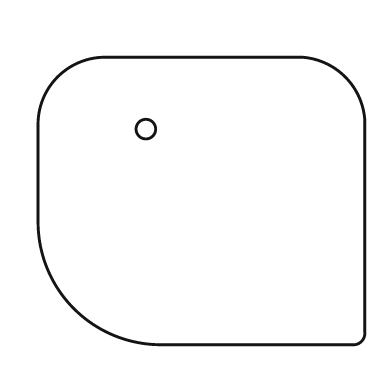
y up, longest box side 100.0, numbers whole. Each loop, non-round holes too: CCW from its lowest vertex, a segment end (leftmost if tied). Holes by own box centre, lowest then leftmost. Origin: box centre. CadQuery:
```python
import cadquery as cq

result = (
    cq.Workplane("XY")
    .moveTo(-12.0, -44.0)
    .lineTo(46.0, -44.0)
    .threePointArc((49.0, -43.0), (50.0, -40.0))
    .lineTo(50.0, 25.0)
    .threePointArc((44.0, 38.0), (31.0, 44.0))
    .lineTo(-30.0, 44.0)
    .threePointArc((-44.0, 38.0), (-50.0, 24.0))
    .lineTo(-50.0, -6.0)
    .threePointArc((-39.0, -33.0), (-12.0, -44.0))
    .close()
    .moveTo(-17.0, 22.0)
    .circle(3.0)
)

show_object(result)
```